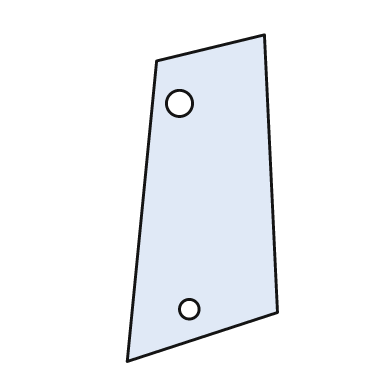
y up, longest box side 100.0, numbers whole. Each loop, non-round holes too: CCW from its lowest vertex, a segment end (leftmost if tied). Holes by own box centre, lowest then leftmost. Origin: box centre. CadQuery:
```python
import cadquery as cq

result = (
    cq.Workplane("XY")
    .moveTo(-23.0, -50.0)
    .lineTo(23.0, -35.0)
    .lineTo(19.0, 50.0)
    .lineTo(-14.0, 42.0)
    .close()
    .moveTo(-4.0, -34.0)
    .circle(3.0)
    .moveTo(-7.0, 29.0)
    .circle(4.0)
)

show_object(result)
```